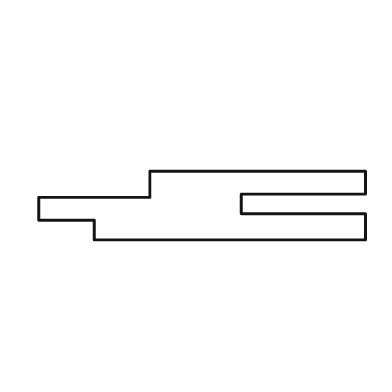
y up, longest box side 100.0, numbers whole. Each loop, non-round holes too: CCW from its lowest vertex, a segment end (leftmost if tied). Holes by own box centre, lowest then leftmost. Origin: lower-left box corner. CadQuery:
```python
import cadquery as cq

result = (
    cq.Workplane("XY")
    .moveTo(17.0, 0.0)
    .lineTo(100.0, 0.0)
    .lineTo(100.0, 8.0)
    .lineTo(62.0, 8.0)
    .lineTo(62.0, 14.0)
    .lineTo(100.0, 14.0)
    .lineTo(100.0, 21.0)
    .lineTo(34.0, 21.0)
    .lineTo(34.0, 13.0)
    .lineTo(0.0, 13.0)
    .lineTo(0.0, 6.0)
    .lineTo(17.0, 6.0)
    .close()
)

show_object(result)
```